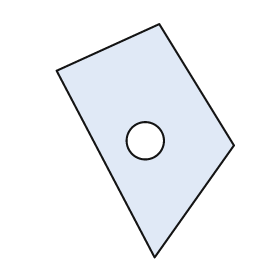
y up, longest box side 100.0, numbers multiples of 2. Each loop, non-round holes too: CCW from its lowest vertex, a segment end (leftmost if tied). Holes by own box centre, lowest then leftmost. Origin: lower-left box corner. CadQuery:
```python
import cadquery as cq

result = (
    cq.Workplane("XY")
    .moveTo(42.0, 0.0)
    .lineTo(76.0, 48.0)
    .lineTo(44.0, 100.0)
    .lineTo(0.0, 80.0)
    .close()
    .moveTo(38.0, 50.0)
    .circle(8.0)
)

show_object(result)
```